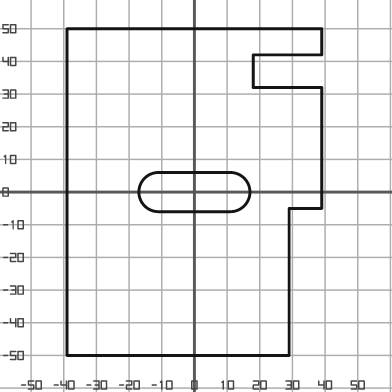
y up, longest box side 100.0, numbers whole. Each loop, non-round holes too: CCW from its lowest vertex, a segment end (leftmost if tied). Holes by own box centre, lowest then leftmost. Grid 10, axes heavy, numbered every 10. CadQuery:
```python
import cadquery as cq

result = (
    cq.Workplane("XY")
    .moveTo(-39.0, -50.0)
    .lineTo(29.0, -50.0)
    .lineTo(29.0, -5.0)
    .lineTo(39.0, -5.0)
    .lineTo(39.0, 32.0)
    .lineTo(18.0, 32.0)
    .lineTo(18.0, 42.0)
    .lineTo(39.0, 42.0)
    .lineTo(39.0, 50.0)
    .lineTo(-39.0, 50.0)
    .close()
    .moveTo(-11.0, -6.0)
    .lineTo(11.0, -6.0)
    .threePointArc((17.0, 0.0), (11.0, 6.0))
    .lineTo(-11.0, 6.0)
    .threePointArc((-17.0, 0.0), (-11.0, -6.0))
    .close()
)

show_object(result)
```